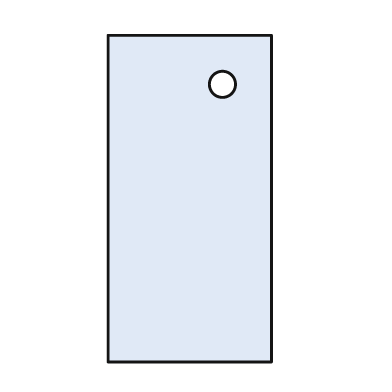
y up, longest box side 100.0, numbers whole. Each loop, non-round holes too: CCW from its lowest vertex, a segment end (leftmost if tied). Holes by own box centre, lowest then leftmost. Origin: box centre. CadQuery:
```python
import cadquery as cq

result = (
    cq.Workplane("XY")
    .moveTo(-25.0, -50.0)
    .lineTo(25.0, -50.0)
    .lineTo(25.0, 50.0)
    .lineTo(-25.0, 50.0)
    .close()
    .moveTo(10.0, 35.0)
    .circle(4.0)
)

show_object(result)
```